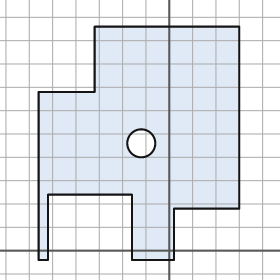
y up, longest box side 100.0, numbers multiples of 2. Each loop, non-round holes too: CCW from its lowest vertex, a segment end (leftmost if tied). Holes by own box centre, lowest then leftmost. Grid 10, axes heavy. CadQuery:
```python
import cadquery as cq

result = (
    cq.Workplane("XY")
    .moveTo(-56.0, -4.0)
    .lineTo(-52.0, -4.0)
    .lineTo(-52.0, 24.0)
    .lineTo(-16.0, 24.0)
    .lineTo(-16.0, -4.0)
    .lineTo(2.0, -4.0)
    .lineTo(2.0, 18.0)
    .lineTo(30.0, 18.0)
    .lineTo(30.0, 96.0)
    .lineTo(-32.0, 96.0)
    .lineTo(-32.0, 68.0)
    .lineTo(-56.0, 68.0)
    .close()
    .moveTo(-12.0, 46.0)
    .circle(6.0)
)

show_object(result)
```